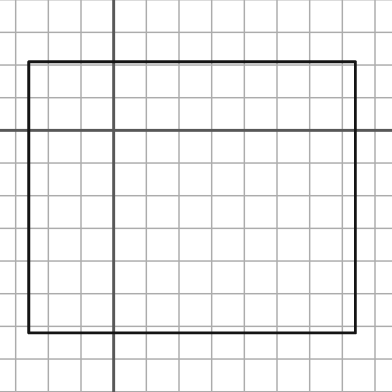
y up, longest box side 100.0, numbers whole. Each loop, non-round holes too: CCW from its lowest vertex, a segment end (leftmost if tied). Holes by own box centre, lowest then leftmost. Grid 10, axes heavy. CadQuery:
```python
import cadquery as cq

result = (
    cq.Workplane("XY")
    .moveTo(-26.0, -62.0)
    .lineTo(74.0, -62.0)
    .lineTo(74.0, 21.0)
    .lineTo(-26.0, 21.0)
    .close()
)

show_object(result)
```